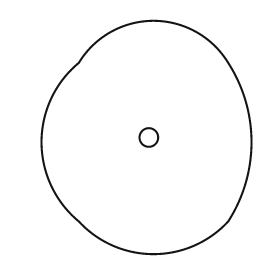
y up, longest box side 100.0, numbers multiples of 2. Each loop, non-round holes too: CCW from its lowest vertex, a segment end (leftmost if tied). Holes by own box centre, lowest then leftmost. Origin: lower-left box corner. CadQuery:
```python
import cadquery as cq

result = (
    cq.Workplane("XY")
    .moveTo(16.0, 14.0)
    .threePointArc((48.0, 0.0), (80.0, 14.0))
    .threePointArc((90.0, 48.0), (80.0, 82.0))
    .threePointArc((48.0, 100.0), (16.0, 82.0))
    .threePointArc((0.0, 48.0), (16.0, 14.0))
    .close()
    .moveTo(46.0, 50.0)
    .circle(4.0)
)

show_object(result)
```